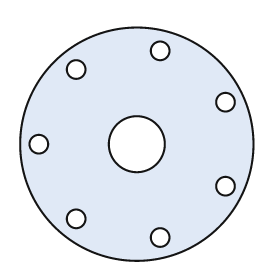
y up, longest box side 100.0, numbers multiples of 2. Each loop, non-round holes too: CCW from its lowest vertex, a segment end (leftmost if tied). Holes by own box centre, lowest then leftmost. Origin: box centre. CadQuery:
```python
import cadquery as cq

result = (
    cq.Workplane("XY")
    .moveTo(0.0, 0.0)
    .circle(50.0)
    .moveTo(10.0, -40.0)
    .circle(4.0)
    .moveTo(-26.0, -32.0)
    .circle(4.0)
    .moveTo(38.0, -18.0)
    .circle(4.0)
    .moveTo(-42.0, 0.0)
    .circle(4.0)
    .moveTo(0.0, 0.0)
    .circle(12.0)
    .moveTo(38.0, 18.0)
    .circle(4.0)
    .moveTo(-26.0, 32.0)
    .circle(4.0)
    .moveTo(10.0, 40.0)
    .circle(4.0)
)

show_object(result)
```